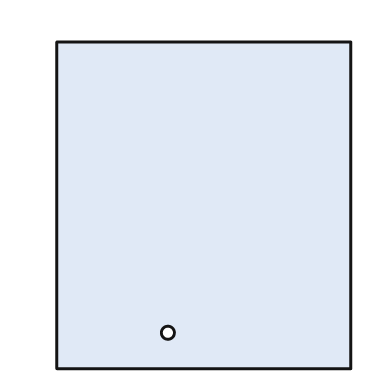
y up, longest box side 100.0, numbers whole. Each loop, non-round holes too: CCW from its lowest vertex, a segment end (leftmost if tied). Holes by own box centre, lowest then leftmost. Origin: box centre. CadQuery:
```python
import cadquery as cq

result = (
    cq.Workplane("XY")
    .moveTo(-45.0, -50.0)
    .lineTo(45.0, -50.0)
    .lineTo(45.0, 50.0)
    .lineTo(-45.0, 50.0)
    .close()
    .moveTo(-11.0, -39.0)
    .circle(2.0)
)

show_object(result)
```